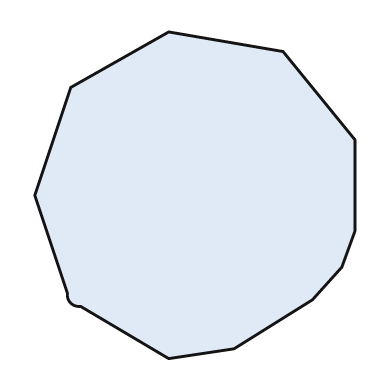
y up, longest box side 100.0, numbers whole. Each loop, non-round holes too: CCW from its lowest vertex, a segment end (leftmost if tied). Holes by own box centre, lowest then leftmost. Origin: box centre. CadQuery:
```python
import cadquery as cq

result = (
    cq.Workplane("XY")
    .moveTo(-8.0, -50.0)
    .lineTo(12.0, -47.0)
    .lineTo(36.0, -32.0)
    .lineTo(45.0, -22.0)
    .lineTo(49.0, -11.0)
    .lineTo(49.0, 17.0)
    .lineTo(27.0, 44.0)
    .lineTo(-8.0, 50.0)
    .lineTo(-38.0, 33.0)
    .lineTo(-49.0, 0.0)
    .lineTo(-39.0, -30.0)
    .threePointArc((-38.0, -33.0), (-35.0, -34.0))
    .close()
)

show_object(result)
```